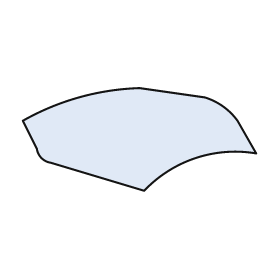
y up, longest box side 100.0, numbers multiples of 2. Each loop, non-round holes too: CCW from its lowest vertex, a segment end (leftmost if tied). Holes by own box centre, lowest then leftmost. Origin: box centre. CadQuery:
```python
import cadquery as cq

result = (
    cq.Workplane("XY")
    .moveTo(2.0, -22.0)
    .threePointArc((24.0, -8.0), (50.0, -6.0))
    .lineTo(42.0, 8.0)
    .threePointArc((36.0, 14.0), (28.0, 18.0))
    .lineTo(0.0, 22.0)
    .threePointArc((-26.0, 18.0), (-50.0, 8.0))
    .lineTo(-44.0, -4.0)
    .threePointArc((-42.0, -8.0), (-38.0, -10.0))
    .close()
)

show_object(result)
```